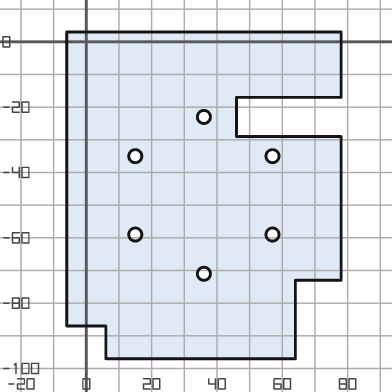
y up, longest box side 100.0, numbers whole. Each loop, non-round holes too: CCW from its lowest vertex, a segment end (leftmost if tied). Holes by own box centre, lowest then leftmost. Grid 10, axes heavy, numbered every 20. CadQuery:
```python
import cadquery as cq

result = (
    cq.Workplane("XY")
    .moveTo(6.0, -97.0)
    .lineTo(64.0, -97.0)
    .lineTo(64.0, -73.0)
    .lineTo(78.0, -73.0)
    .lineTo(78.0, -29.0)
    .lineTo(46.0, -29.0)
    .lineTo(46.0, -17.0)
    .lineTo(78.0, -17.0)
    .lineTo(78.0, 3.0)
    .lineTo(-6.0, 3.0)
    .lineTo(-6.0, -87.0)
    .lineTo(6.0, -87.0)
    .close()
    .moveTo(36.0, -71.0)
    .circle(2.0)
    .moveTo(15.0, -59.0)
    .circle(2.0)
    .moveTo(57.0, -59.0)
    .circle(2.0)
    .moveTo(15.0, -35.0)
    .circle(2.0)
    .moveTo(57.0, -35.0)
    .circle(2.0)
    .moveTo(36.0, -23.0)
    .circle(2.0)
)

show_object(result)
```